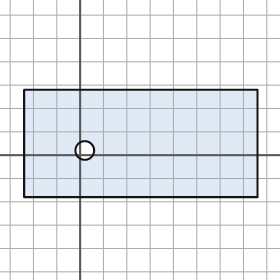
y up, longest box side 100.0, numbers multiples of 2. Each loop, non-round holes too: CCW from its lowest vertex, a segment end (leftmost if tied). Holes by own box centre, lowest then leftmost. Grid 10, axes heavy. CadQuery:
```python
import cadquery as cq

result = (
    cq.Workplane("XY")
    .moveTo(-24.0, -18.0)
    .lineTo(76.0, -18.0)
    .lineTo(76.0, 28.0)
    .lineTo(-24.0, 28.0)
    .close()
    .moveTo(2.0, 2.0)
    .circle(4.0)
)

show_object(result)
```